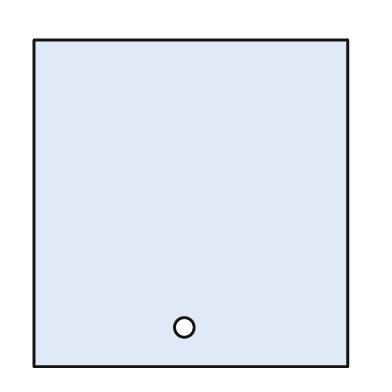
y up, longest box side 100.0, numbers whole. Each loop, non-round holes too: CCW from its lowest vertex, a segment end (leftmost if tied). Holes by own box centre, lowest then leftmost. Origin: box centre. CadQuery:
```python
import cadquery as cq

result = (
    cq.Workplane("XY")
    .moveTo(-48.0, -50.0)
    .lineTo(48.0, -50.0)
    .lineTo(48.0, 50.0)
    .lineTo(-48.0, 50.0)
    .close()
    .moveTo(-2.0, -38.0)
    .circle(3.0)
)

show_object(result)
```